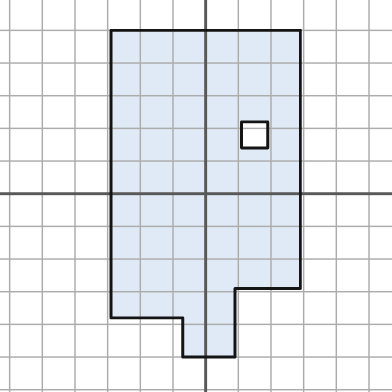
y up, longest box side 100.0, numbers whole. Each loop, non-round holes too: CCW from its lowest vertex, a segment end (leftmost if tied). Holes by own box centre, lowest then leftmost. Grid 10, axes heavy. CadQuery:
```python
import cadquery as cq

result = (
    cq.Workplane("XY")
    .moveTo(-7.0, -50.0)
    .lineTo(9.0, -50.0)
    .lineTo(9.0, -29.0)
    .lineTo(29.0, -29.0)
    .lineTo(29.0, 50.0)
    .lineTo(-29.0, 50.0)
    .lineTo(-29.0, -38.0)
    .lineTo(-7.0, -38.0)
    .close()
    .moveTo(11.0, 14.0)
    .lineTo(19.0, 14.0)
    .lineTo(19.0, 22.0)
    .lineTo(11.0, 22.0)
    .close()
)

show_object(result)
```